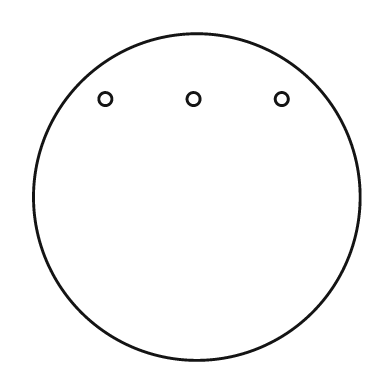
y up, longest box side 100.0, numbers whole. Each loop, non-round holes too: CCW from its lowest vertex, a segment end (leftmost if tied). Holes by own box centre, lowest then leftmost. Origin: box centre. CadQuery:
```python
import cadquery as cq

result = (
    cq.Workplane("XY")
    .moveTo(0.0, 0.0)
    .circle(50.0)
    .moveTo(-28.0, 30.0)
    .circle(2.0)
    .moveTo(-1.0, 30.0)
    .circle(2.0)
    .moveTo(26.0, 30.0)
    .circle(2.0)
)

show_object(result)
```